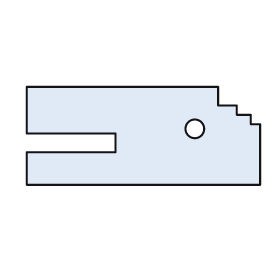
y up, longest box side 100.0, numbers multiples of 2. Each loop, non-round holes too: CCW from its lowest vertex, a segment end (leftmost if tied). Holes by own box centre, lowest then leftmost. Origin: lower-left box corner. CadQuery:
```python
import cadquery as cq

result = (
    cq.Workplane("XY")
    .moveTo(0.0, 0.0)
    .lineTo(100.0, 0.0)
    .lineTo(100.0, 26.0)
    .lineTo(96.0, 26.0)
    .lineTo(96.0, 30.0)
    .lineTo(90.0, 30.0)
    .lineTo(90.0, 34.0)
    .lineTo(82.0, 34.0)
    .lineTo(82.0, 42.0)
    .lineTo(0.0, 42.0)
    .lineTo(0.0, 22.0)
    .lineTo(38.0, 22.0)
    .lineTo(38.0, 14.0)
    .lineTo(0.0, 14.0)
    .close()
    .moveTo(72.0, 24.0)
    .circle(4.0)
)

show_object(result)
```